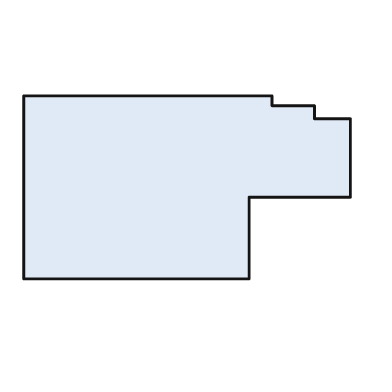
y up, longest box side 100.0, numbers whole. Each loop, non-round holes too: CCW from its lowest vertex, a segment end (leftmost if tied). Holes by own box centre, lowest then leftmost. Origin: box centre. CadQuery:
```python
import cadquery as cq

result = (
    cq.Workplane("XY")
    .moveTo(-50.0, -28.0)
    .lineTo(19.0, -28.0)
    .lineTo(19.0, -3.0)
    .lineTo(50.0, -3.0)
    .lineTo(50.0, 21.0)
    .lineTo(39.0, 21.0)
    .lineTo(39.0, 25.0)
    .lineTo(26.0, 25.0)
    .lineTo(26.0, 28.0)
    .lineTo(-50.0, 28.0)
    .close()
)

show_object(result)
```